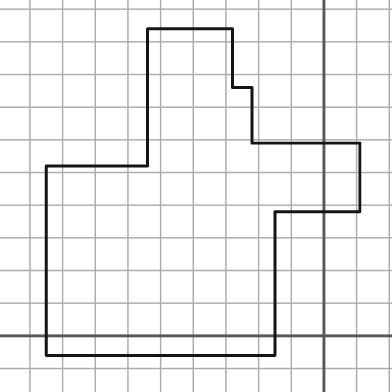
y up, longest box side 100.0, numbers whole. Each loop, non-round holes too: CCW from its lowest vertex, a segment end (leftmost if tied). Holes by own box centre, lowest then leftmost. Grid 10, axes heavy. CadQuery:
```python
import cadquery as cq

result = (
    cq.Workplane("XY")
    .moveTo(-85.0, -6.0)
    .lineTo(-15.0, -6.0)
    .lineTo(-15.0, 38.0)
    .lineTo(11.0, 38.0)
    .lineTo(11.0, 59.0)
    .lineTo(-22.0, 59.0)
    .lineTo(-22.0, 76.0)
    .lineTo(-28.0, 76.0)
    .lineTo(-28.0, 94.0)
    .lineTo(-54.0, 94.0)
    .lineTo(-54.0, 52.0)
    .lineTo(-85.0, 52.0)
    .close()
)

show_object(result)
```